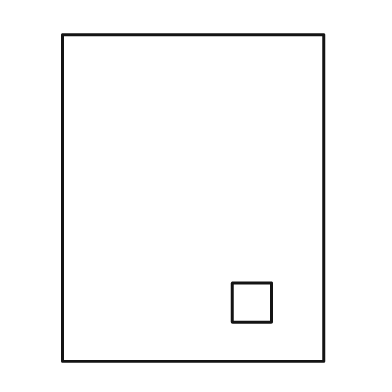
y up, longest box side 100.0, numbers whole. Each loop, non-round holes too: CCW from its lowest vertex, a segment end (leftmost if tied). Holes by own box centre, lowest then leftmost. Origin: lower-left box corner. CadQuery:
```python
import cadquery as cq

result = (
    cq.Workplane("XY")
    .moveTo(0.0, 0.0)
    .lineTo(80.0, 0.0)
    .lineTo(80.0, 100.0)
    .lineTo(0.0, 100.0)
    .close()
    .moveTo(52.0, 12.0)
    .lineTo(64.0, 12.0)
    .lineTo(64.0, 24.0)
    .lineTo(52.0, 24.0)
    .close()
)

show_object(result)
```